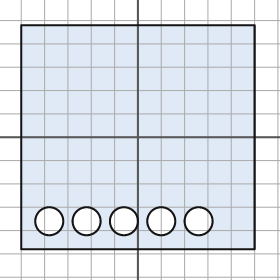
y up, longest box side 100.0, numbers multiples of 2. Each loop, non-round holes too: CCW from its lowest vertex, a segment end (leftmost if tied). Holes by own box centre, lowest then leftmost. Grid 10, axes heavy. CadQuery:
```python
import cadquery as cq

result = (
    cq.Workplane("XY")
    .moveTo(-50.0, -48.0)
    .lineTo(50.0, -48.0)
    .lineTo(50.0, 48.0)
    .lineTo(-50.0, 48.0)
    .close()
    .moveTo(-38.0, -36.0)
    .circle(6.0)
    .moveTo(-22.0, -36.0)
    .circle(6.0)
    .moveTo(-6.0, -36.0)
    .circle(6.0)
    .moveTo(10.0, -36.0)
    .circle(6.0)
    .moveTo(26.0, -36.0)
    .circle(6.0)
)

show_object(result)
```